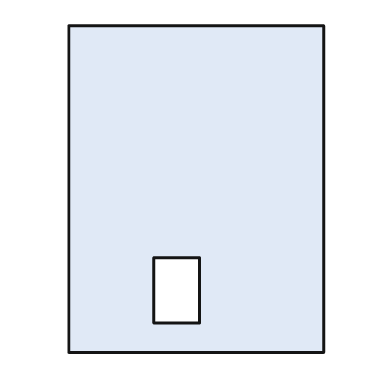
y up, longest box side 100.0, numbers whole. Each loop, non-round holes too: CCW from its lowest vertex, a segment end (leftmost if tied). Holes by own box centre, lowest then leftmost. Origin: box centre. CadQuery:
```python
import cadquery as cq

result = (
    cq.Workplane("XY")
    .moveTo(-39.0, -50.0)
    .lineTo(39.0, -50.0)
    .lineTo(39.0, 50.0)
    .lineTo(-39.0, 50.0)
    .close()
    .moveTo(-13.0, -41.0)
    .lineTo(1.0, -41.0)
    .lineTo(1.0, -21.0)
    .lineTo(-13.0, -21.0)
    .close()
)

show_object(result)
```